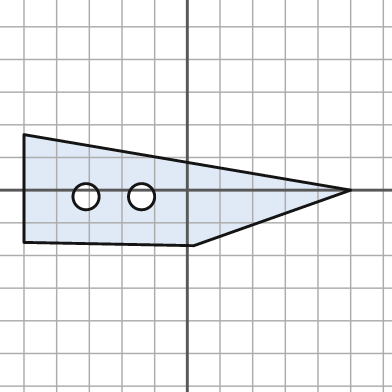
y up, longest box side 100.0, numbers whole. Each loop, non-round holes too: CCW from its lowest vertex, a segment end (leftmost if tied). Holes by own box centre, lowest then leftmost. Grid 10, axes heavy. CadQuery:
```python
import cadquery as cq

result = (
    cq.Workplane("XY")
    .moveTo(2.0, -17.0)
    .lineTo(50.0, 0.0)
    .lineTo(-50.0, 17.0)
    .lineTo(-50.0, -16.0)
    .close()
    .moveTo(-31.0, -2.0)
    .circle(4.0)
    .moveTo(-14.0, -2.0)
    .circle(4.0)
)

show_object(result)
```